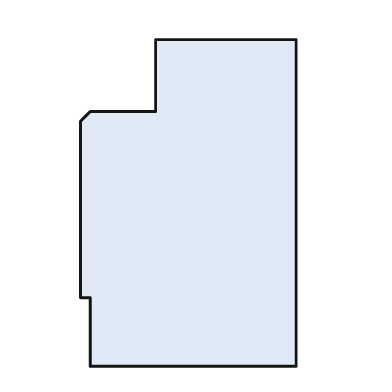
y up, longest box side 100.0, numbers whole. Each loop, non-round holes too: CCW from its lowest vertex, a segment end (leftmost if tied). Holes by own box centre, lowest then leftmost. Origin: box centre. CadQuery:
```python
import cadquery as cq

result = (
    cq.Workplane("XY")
    .moveTo(-30.0, -50.0)
    .lineTo(33.0, -50.0)
    .lineTo(33.0, 50.0)
    .lineTo(-10.0, 50.0)
    .lineTo(-10.0, 28.0)
    .lineTo(-30.0, 28.0)
    .lineTo(-33.0, 25.0)
    .lineTo(-33.0, -29.0)
    .lineTo(-30.0, -29.0)
    .close()
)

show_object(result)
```